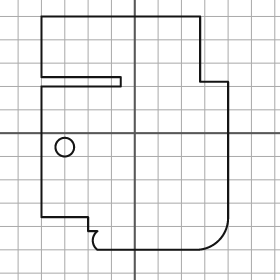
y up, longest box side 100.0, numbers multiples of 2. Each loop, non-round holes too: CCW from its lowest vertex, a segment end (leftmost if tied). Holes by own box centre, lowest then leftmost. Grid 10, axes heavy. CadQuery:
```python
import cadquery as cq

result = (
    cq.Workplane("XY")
    .moveTo(-16.0, -50.0)
    .lineTo(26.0, -50.0)
    .threePointArc((36.0, -46.0), (40.0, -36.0))
    .lineTo(40.0, 22.0)
    .lineTo(28.0, 22.0)
    .lineTo(28.0, 50.0)
    .lineTo(-40.0, 50.0)
    .lineTo(-40.0, 24.0)
    .lineTo(-6.0, 24.0)
    .lineTo(-6.0, 20.0)
    .lineTo(-40.0, 20.0)
    .lineTo(-40.0, -36.0)
    .lineTo(-20.0, -36.0)
    .lineTo(-20.0, -42.0)
    .lineTo(-16.0, -42.0)
    .threePointArc((-18.0, -46.0), (-16.0, -50.0))
    .close()
    .moveTo(-30.0, -6.0)
    .circle(4.0)
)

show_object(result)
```